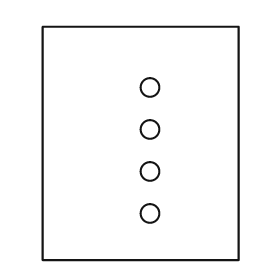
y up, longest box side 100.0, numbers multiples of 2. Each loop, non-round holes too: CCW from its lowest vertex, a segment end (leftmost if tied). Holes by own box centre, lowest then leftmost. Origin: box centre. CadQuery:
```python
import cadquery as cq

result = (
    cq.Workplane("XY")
    .moveTo(-42.0, -50.0)
    .lineTo(42.0, -50.0)
    .lineTo(42.0, 50.0)
    .lineTo(-42.0, 50.0)
    .close()
    .moveTo(4.0, -30.0)
    .circle(4.0)
    .moveTo(4.0, -12.0)
    .circle(4.0)
    .moveTo(4.0, 6.0)
    .circle(4.0)
    .moveTo(4.0, 24.0)
    .circle(4.0)
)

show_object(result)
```